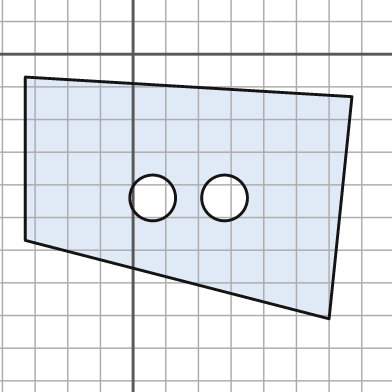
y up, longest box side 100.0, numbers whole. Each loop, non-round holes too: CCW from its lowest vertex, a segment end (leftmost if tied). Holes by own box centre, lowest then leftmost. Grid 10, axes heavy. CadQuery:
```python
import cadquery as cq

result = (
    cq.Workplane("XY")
    .moveTo(60.0, -81.0)
    .lineTo(67.0, -13.0)
    .lineTo(-33.0, -7.0)
    .lineTo(-33.0, -57.0)
    .close()
    .moveTo(6.0, -44.0)
    .circle(7.0)
    .moveTo(28.0, -44.0)
    .circle(7.0)
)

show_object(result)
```